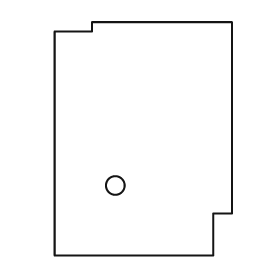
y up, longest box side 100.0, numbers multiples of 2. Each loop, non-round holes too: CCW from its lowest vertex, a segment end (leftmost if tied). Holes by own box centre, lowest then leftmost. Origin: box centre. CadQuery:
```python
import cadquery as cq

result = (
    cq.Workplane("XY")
    .moveTo(-38.0, -50.0)
    .lineTo(30.0, -50.0)
    .lineTo(30.0, -32.0)
    .lineTo(38.0, -32.0)
    .lineTo(38.0, 50.0)
    .lineTo(-22.0, 50.0)
    .lineTo(-22.0, 46.0)
    .lineTo(-38.0, 46.0)
    .close()
    .moveTo(-12.0, -20.0)
    .circle(4.0)
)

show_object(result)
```